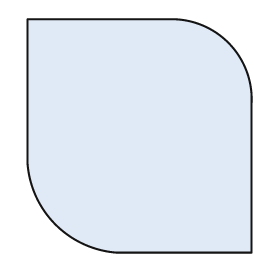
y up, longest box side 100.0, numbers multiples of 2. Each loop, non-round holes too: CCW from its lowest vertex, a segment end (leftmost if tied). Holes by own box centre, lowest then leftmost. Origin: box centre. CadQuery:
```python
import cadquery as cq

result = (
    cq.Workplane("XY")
    .moveTo(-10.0, -50.0)
    .lineTo(48.0, -50.0)
    .lineTo(48.0, 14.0)
    .threePointArc((38.0, 40.0), (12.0, 50.0))
    .lineTo(-48.0, 50.0)
    .lineTo(-48.0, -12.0)
    .threePointArc((-36.0, -38.0), (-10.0, -50.0))
    .close()
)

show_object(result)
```